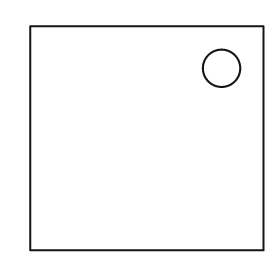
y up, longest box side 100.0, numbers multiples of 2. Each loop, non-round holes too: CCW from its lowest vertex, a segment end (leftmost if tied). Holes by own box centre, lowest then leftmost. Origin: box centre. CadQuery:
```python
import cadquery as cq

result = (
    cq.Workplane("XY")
    .moveTo(-50.0, -48.0)
    .lineTo(50.0, -48.0)
    .lineTo(50.0, 48.0)
    .lineTo(-50.0, 48.0)
    .close()
    .moveTo(32.0, 30.0)
    .circle(8.0)
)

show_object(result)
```